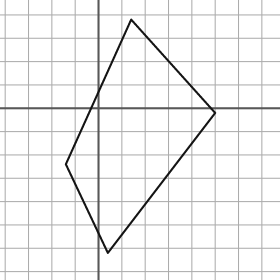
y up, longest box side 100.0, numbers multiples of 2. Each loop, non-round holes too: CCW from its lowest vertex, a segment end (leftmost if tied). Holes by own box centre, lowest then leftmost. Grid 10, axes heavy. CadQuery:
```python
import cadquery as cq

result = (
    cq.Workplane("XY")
    .moveTo(4.0, -62.0)
    .lineTo(50.0, -2.0)
    .lineTo(14.0, 38.0)
    .lineTo(-14.0, -24.0)
    .close()
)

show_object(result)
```